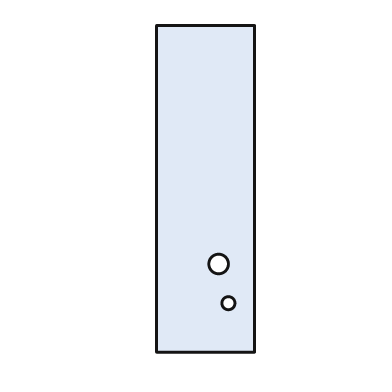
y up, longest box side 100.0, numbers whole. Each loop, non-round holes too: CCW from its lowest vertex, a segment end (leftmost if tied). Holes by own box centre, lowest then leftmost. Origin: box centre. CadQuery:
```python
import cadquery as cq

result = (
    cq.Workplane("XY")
    .moveTo(-15.0, -50.0)
    .lineTo(15.0, -50.0)
    .lineTo(15.0, 50.0)
    .lineTo(-15.0, 50.0)
    .close()
    .moveTo(7.0, -35.0)
    .circle(2.0)
    .moveTo(4.0, -23.0)
    .circle(3.0)
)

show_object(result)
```